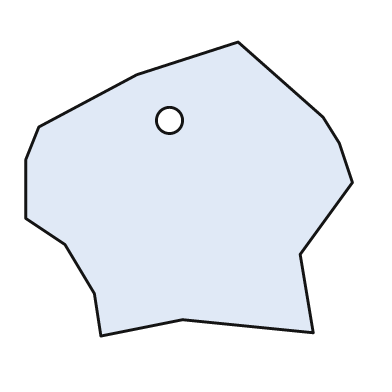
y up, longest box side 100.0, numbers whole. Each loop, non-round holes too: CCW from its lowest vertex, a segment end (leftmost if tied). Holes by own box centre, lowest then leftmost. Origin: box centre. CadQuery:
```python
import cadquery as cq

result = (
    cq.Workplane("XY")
    .moveTo(-27.0, -45.0)
    .lineTo(-2.0, -40.0)
    .lineTo(38.0, -44.0)
    .lineTo(34.0, -20.0)
    .lineTo(50.0, 2.0)
    .lineTo(46.0, 14.0)
    .lineTo(41.0, 22.0)
    .lineTo(15.0, 45.0)
    .lineTo(-16.0, 35.0)
    .lineTo(-46.0, 19.0)
    .lineTo(-50.0, 9.0)
    .lineTo(-50.0, -9.0)
    .lineTo(-38.0, -17.0)
    .lineTo(-29.0, -32.0)
    .close()
    .moveTo(-6.0, 21.0)
    .circle(4.0)
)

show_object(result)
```